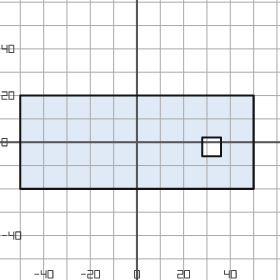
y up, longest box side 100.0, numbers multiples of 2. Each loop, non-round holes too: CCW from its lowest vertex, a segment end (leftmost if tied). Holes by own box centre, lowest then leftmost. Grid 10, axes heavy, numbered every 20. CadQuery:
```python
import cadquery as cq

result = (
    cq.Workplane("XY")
    .moveTo(-50.0, -20.0)
    .lineTo(50.0, -20.0)
    .lineTo(50.0, 20.0)
    .lineTo(-50.0, 20.0)
    .close()
    .moveTo(28.0, -6.0)
    .lineTo(36.0, -6.0)
    .lineTo(36.0, 2.0)
    .lineTo(28.0, 2.0)
    .close()
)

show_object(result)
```